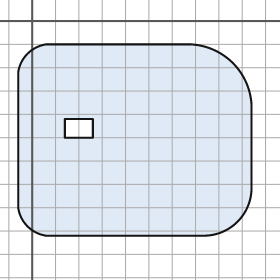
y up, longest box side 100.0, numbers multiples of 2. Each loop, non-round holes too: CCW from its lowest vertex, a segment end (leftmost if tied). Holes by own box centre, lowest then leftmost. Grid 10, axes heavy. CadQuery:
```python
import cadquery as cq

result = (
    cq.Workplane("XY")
    .moveTo(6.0, -92.0)
    .lineTo(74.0, -92.0)
    .threePointArc((88.0, -86.0), (94.0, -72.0))
    .lineTo(94.0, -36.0)
    .threePointArc((86.0, -18.0), (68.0, -10.0))
    .lineTo(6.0, -10.0)
    .threePointArc((-2.0, -14.0), (-6.0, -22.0))
    .lineTo(-6.0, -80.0)
    .threePointArc((-2.0, -88.0), (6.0, -92.0))
    .close()
    .moveTo(14.0, -50.0)
    .lineTo(26.0, -50.0)
    .lineTo(26.0, -42.0)
    .lineTo(14.0, -42.0)
    .close()
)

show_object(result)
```